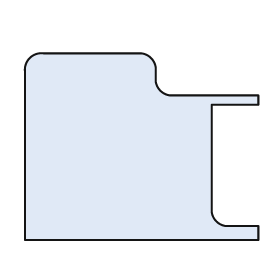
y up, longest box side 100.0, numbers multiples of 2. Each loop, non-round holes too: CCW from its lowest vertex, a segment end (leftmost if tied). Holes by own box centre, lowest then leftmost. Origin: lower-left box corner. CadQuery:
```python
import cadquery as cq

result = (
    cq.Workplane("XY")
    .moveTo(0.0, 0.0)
    .lineTo(100.0, 0.0)
    .lineTo(100.0, 6.0)
    .lineTo(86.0, 6.0)
    .threePointArc((82.0, 8.0), (80.0, 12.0))
    .lineTo(80.0, 58.0)
    .lineTo(100.0, 58.0)
    .lineTo(100.0, 62.0)
    .lineTo(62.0, 62.0)
    .threePointArc((58.0, 64.0), (56.0, 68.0))
    .lineTo(56.0, 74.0)
    .threePointArc((54.0, 78.0), (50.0, 80.0))
    .lineTo(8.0, 80.0)
    .threePointArc((2.0, 78.0), (0.0, 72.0))
    .close()
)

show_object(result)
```